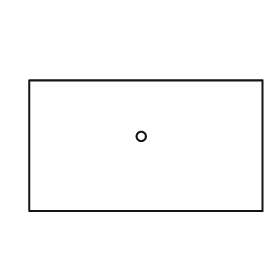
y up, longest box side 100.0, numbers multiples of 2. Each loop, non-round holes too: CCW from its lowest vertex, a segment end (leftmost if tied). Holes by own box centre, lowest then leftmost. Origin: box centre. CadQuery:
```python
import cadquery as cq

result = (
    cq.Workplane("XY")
    .moveTo(-50.0, -28.0)
    .lineTo(50.0, -28.0)
    .lineTo(50.0, 28.0)
    .lineTo(-50.0, 28.0)
    .close()
    .moveTo(-2.0, 4.0)
    .circle(2.0)
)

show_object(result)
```